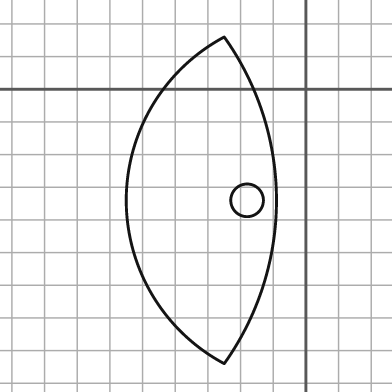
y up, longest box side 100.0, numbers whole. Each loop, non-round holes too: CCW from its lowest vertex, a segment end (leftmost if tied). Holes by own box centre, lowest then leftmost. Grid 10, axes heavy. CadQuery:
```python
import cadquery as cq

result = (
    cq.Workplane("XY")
    .moveTo(-25.0, -84.0)
    .threePointArc((-9.0, -34.0), (-25.0, 16.0))
    .threePointArc((-55.0, -34.0), (-25.0, -84.0))
    .close()
    .moveTo(-18.0, -34.0)
    .circle(5.0)
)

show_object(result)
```